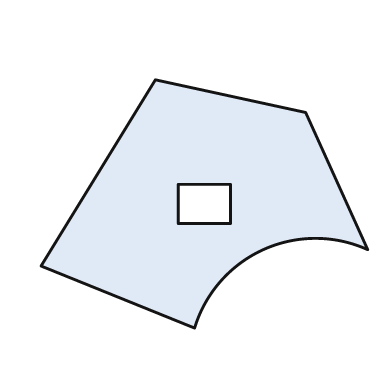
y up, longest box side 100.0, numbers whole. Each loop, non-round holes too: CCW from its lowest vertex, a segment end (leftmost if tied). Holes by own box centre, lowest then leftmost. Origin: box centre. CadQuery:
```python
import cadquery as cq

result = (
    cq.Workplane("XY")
    .moveTo(-3.0, -38.0)
    .threePointArc((18.0, -14.0), (50.0, -14.0))
    .lineTo(31.0, 28.0)
    .lineTo(-15.0, 38.0)
    .lineTo(-50.0, -19.0)
    .close()
    .moveTo(-8.0, -6.0)
    .lineTo(8.0, -6.0)
    .lineTo(8.0, 6.0)
    .lineTo(-8.0, 6.0)
    .close()
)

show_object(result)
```